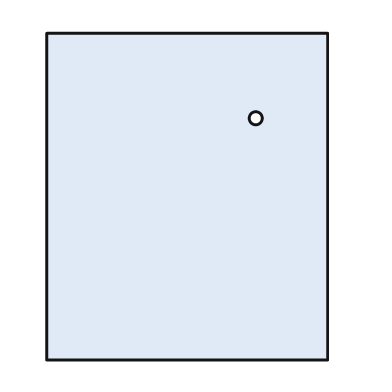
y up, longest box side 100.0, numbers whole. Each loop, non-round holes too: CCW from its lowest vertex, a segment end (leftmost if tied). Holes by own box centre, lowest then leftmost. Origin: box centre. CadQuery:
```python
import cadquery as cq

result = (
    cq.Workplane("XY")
    .moveTo(-43.0, -50.0)
    .lineTo(43.0, -50.0)
    .lineTo(43.0, 50.0)
    .lineTo(-43.0, 50.0)
    .close()
    .moveTo(21.0, 24.0)
    .circle(2.0)
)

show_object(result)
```